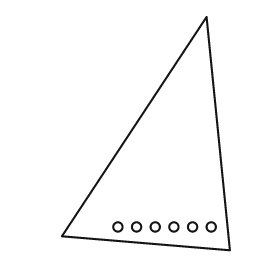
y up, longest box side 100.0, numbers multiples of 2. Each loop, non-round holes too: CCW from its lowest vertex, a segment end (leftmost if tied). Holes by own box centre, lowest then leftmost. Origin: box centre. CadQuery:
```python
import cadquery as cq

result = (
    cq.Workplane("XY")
    .moveTo(36.0, -50.0)
    .lineTo(26.0, 50.0)
    .lineTo(-36.0, -44.0)
    .close()
    .moveTo(-12.0, -40.0)
    .circle(2.0)
    .moveTo(-4.0, -40.0)
    .circle(2.0)
    .moveTo(4.0, -40.0)
    .circle(2.0)
    .moveTo(12.0, -40.0)
    .circle(2.0)
    .moveTo(20.0, -40.0)
    .circle(2.0)
    .moveTo(28.0, -40.0)
    .circle(2.0)
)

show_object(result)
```